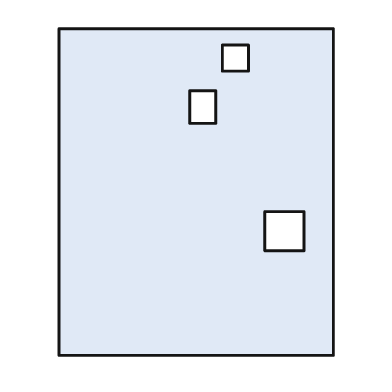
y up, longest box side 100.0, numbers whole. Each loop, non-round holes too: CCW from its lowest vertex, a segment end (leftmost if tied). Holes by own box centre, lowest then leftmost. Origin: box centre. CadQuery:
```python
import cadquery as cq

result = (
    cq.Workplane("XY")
    .moveTo(-42.0, -50.0)
    .lineTo(42.0, -50.0)
    .lineTo(42.0, 50.0)
    .lineTo(-42.0, 50.0)
    .close()
    .moveTo(21.0, -18.0)
    .lineTo(33.0, -18.0)
    .lineTo(33.0, -6.0)
    .lineTo(21.0, -6.0)
    .close()
    .moveTo(-2.0, 21.0)
    .lineTo(6.0, 21.0)
    .lineTo(6.0, 31.0)
    .lineTo(-2.0, 31.0)
    .close()
    .moveTo(8.0, 37.0)
    .lineTo(16.0, 37.0)
    .lineTo(16.0, 45.0)
    .lineTo(8.0, 45.0)
    .close()
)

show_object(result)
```